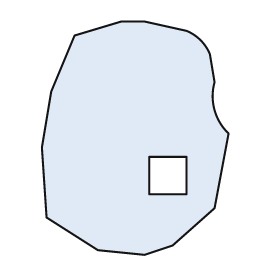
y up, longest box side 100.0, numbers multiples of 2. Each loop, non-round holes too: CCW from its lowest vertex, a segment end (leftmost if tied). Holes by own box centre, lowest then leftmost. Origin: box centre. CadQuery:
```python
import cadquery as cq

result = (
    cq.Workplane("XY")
    .moveTo(4.0, -50.0)
    .lineTo(16.0, -46.0)
    .lineTo(34.0, -30.0)
    .lineTo(40.0, 2.0)
    .threePointArc((34.0, 12.0), (34.0, 24.0))
    .lineTo(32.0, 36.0)
    .threePointArc((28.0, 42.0), (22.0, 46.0))
    .lineTo(4.0, 50.0)
    .lineTo(-6.0, 50.0)
    .lineTo(-26.0, 44.0)
    .lineTo(-36.0, 20.0)
    .lineTo(-40.0, -4.0)
    .lineTo(-38.0, -34.0)
    .lineTo(-16.0, -48.0)
    .close()
    .moveTo(6.0, -24.0)
    .lineTo(22.0, -24.0)
    .lineTo(22.0, -8.0)
    .lineTo(6.0, -8.0)
    .close()
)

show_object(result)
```